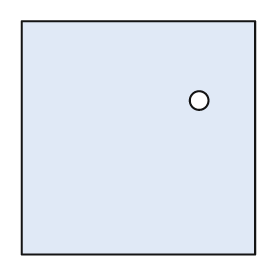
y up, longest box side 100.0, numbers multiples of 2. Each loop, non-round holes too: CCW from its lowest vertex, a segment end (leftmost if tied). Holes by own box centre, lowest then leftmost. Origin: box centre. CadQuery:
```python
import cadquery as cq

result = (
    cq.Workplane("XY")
    .moveTo(-50.0, -50.0)
    .lineTo(50.0, -50.0)
    .lineTo(50.0, 50.0)
    .lineTo(-50.0, 50.0)
    .close()
    .moveTo(26.0, 16.0)
    .circle(4.0)
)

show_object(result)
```